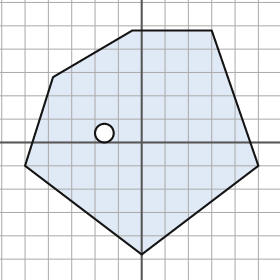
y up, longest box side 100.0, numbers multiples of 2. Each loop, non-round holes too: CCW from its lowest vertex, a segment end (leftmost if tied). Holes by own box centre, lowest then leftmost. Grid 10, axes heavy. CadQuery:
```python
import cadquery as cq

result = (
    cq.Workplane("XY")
    .moveTo(0.0, -48.0)
    .lineTo(50.0, -10.0)
    .lineTo(30.0, 48.0)
    .lineTo(-4.0, 48.0)
    .lineTo(-38.0, 28.0)
    .lineTo(-50.0, -10.0)
    .close()
    .moveTo(-16.0, 4.0)
    .circle(4.0)
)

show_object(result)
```